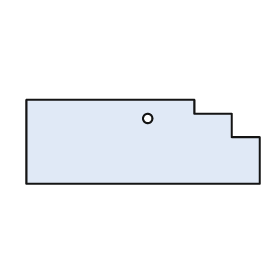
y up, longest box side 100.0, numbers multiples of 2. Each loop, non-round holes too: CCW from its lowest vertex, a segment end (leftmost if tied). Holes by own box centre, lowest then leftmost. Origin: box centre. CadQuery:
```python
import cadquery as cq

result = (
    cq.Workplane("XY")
    .moveTo(-50.0, -18.0)
    .lineTo(50.0, -18.0)
    .lineTo(50.0, 2.0)
    .lineTo(38.0, 2.0)
    .lineTo(38.0, 12.0)
    .lineTo(22.0, 12.0)
    .lineTo(22.0, 18.0)
    .lineTo(-50.0, 18.0)
    .close()
    .moveTo(2.0, 10.0)
    .circle(2.0)
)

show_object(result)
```